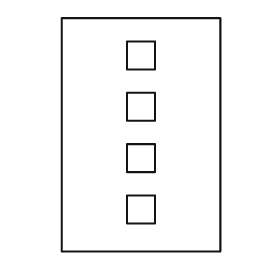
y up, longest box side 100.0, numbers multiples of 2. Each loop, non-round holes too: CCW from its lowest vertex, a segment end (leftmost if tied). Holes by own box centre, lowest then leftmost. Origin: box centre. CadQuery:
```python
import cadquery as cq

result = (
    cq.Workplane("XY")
    .moveTo(-34.0, -50.0)
    .lineTo(34.0, -50.0)
    .lineTo(34.0, 50.0)
    .lineTo(-34.0, 50.0)
    .close()
    .moveTo(-6.0, -38.0)
    .lineTo(6.0, -38.0)
    .lineTo(6.0, -26.0)
    .lineTo(-6.0, -26.0)
    .close()
    .moveTo(-6.0, -16.0)
    .lineTo(6.0, -16.0)
    .lineTo(6.0, -4.0)
    .lineTo(-6.0, -4.0)
    .close()
    .moveTo(-6.0, 6.0)
    .lineTo(6.0, 6.0)
    .lineTo(6.0, 18.0)
    .lineTo(-6.0, 18.0)
    .close()
    .moveTo(-6.0, 28.0)
    .lineTo(6.0, 28.0)
    .lineTo(6.0, 40.0)
    .lineTo(-6.0, 40.0)
    .close()
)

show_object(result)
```